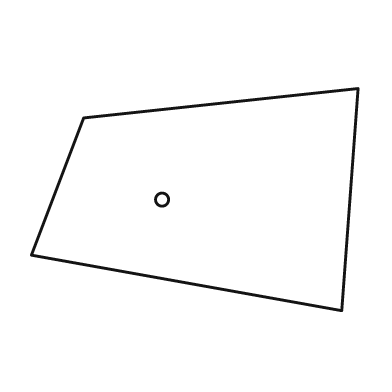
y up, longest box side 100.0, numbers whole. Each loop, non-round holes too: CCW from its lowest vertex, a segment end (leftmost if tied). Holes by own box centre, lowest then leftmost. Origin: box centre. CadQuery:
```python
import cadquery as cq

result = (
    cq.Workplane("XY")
    .moveTo(45.0, -34.0)
    .lineTo(50.0, 34.0)
    .lineTo(-34.0, 25.0)
    .lineTo(-50.0, -17.0)
    .close()
    .moveTo(-10.0, 0.0)
    .circle(2.0)
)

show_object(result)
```